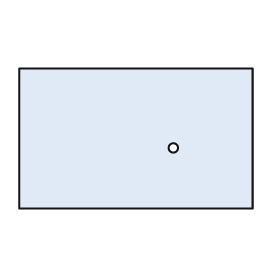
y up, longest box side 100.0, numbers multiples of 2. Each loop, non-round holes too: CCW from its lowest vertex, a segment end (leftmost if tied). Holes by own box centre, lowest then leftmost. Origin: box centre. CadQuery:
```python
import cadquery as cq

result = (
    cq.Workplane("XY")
    .moveTo(-50.0, -30.0)
    .lineTo(50.0, -30.0)
    .lineTo(50.0, 30.0)
    .lineTo(-50.0, 30.0)
    .close()
    .moveTo(16.0, -4.0)
    .circle(2.0)
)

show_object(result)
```